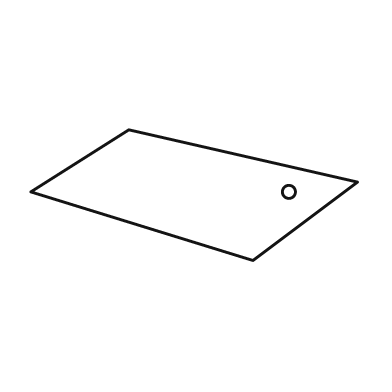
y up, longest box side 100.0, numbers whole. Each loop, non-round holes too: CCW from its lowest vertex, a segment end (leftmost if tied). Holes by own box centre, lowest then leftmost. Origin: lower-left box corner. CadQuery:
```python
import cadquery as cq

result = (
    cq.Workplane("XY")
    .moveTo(68.0, 0.0)
    .lineTo(100.0, 24.0)
    .lineTo(30.0, 40.0)
    .lineTo(0.0, 21.0)
    .close()
    .moveTo(79.0, 21.0)
    .circle(2.0)
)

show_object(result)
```